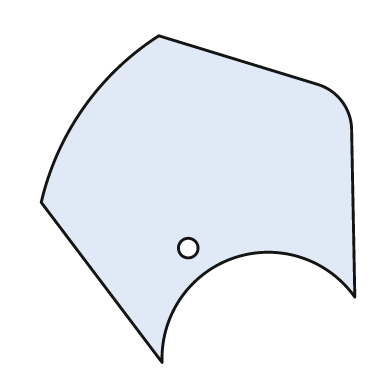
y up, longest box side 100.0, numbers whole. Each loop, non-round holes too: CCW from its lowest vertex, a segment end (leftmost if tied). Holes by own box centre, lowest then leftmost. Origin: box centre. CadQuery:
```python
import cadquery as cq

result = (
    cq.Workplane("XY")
    .moveTo(-11.0, -50.0)
    .threePointArc((11.0, -18.0), (48.0, -30.0))
    .lineTo(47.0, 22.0)
    .threePointArc((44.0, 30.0), (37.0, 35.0))
    .lineTo(-12.0, 50.0)
    .threePointArc((-35.0, 28.0), (-48.0, -1.0))
    .close()
    .moveTo(-3.0, -15.0)
    .circle(3.0)
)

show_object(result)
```